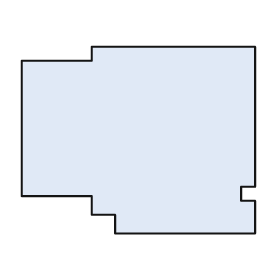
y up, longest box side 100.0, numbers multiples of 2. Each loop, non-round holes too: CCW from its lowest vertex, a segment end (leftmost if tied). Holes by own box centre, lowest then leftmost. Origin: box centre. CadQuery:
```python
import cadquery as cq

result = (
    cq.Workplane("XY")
    .moveTo(-10.0, -40.0)
    .lineTo(50.0, -40.0)
    .lineTo(50.0, -26.0)
    .lineTo(44.0, -26.0)
    .lineTo(44.0, -20.0)
    .lineTo(50.0, -20.0)
    .lineTo(50.0, 40.0)
    .lineTo(-20.0, 40.0)
    .lineTo(-20.0, 34.0)
    .lineTo(-50.0, 34.0)
    .lineTo(-50.0, -24.0)
    .lineTo(-20.0, -24.0)
    .lineTo(-20.0, -32.0)
    .lineTo(-10.0, -32.0)
    .close()
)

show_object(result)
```